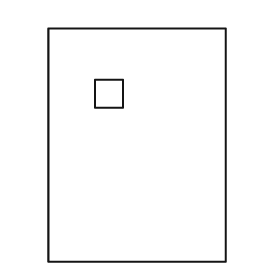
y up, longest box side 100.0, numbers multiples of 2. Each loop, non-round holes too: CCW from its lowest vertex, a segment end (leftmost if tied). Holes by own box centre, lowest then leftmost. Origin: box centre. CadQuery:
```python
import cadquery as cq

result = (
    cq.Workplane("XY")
    .moveTo(-38.0, -50.0)
    .lineTo(38.0, -50.0)
    .lineTo(38.0, 50.0)
    .lineTo(-38.0, 50.0)
    .close()
    .moveTo(-18.0, 16.0)
    .lineTo(-6.0, 16.0)
    .lineTo(-6.0, 28.0)
    .lineTo(-18.0, 28.0)
    .close()
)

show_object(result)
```